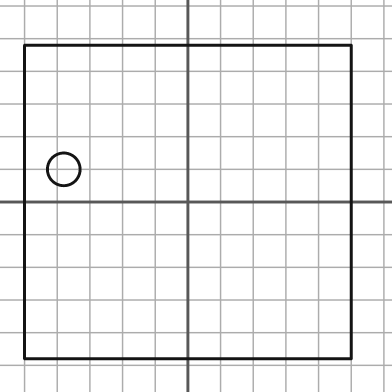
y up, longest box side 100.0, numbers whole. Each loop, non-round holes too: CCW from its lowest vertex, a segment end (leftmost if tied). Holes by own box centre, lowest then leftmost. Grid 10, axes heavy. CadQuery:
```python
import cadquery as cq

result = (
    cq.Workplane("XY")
    .moveTo(-50.0, -48.0)
    .lineTo(50.0, -48.0)
    .lineTo(50.0, 48.0)
    .lineTo(-50.0, 48.0)
    .close()
    .moveTo(-38.0, 10.0)
    .circle(5.0)
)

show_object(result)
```